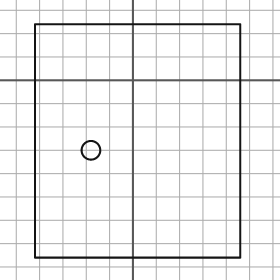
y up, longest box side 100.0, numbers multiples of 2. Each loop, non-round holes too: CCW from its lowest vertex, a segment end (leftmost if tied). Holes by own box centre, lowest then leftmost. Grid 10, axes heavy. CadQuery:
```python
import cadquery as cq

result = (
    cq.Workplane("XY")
    .moveTo(-42.0, -76.0)
    .lineTo(46.0, -76.0)
    .lineTo(46.0, 24.0)
    .lineTo(-42.0, 24.0)
    .close()
    .moveTo(-18.0, -30.0)
    .circle(4.0)
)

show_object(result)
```